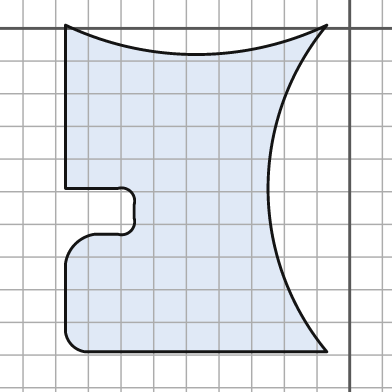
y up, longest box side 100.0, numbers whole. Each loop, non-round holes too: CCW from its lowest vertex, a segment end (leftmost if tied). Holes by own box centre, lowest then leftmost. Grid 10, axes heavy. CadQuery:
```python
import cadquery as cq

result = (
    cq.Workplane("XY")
    .moveTo(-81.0, -99.0)
    .lineTo(-7.0, -99.0)
    .threePointArc((-25.0, -49.0), (-7.0, 1.0))
    .threePointArc((-47.0, -8.0), (-87.0, 1.0))
    .lineTo(-87.0, -49.0)
    .lineTo(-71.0, -49.0)
    .threePointArc((-67.0, -50.0), (-66.0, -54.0))
    .lineTo(-66.0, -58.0)
    .threePointArc((-67.0, -62.0), (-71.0, -63.0))
    .lineTo(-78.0, -63.0)
    .threePointArc((-84.0, -66.0), (-87.0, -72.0))
    .lineTo(-87.0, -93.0)
    .threePointArc((-85.0, -97.0), (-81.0, -99.0))
    .close()
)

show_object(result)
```